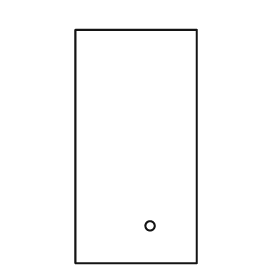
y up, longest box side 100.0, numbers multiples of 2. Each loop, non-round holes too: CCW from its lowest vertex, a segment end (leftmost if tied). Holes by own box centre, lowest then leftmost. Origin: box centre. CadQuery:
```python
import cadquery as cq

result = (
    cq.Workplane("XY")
    .moveTo(-26.0, -50.0)
    .lineTo(26.0, -50.0)
    .lineTo(26.0, 50.0)
    .lineTo(-26.0, 50.0)
    .close()
    .moveTo(6.0, -34.0)
    .circle(2.0)
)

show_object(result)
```